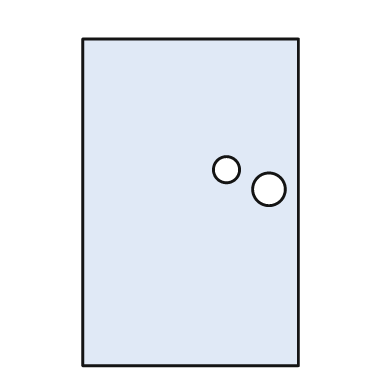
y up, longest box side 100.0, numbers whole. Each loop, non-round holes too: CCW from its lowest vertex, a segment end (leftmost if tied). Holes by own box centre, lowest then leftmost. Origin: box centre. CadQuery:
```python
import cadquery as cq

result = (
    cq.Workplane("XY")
    .moveTo(-33.0, -50.0)
    .lineTo(33.0, -50.0)
    .lineTo(33.0, 50.0)
    .lineTo(-33.0, 50.0)
    .close()
    .moveTo(24.0, 4.0)
    .circle(5.0)
    .moveTo(11.0, 10.0)
    .circle(4.0)
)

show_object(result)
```